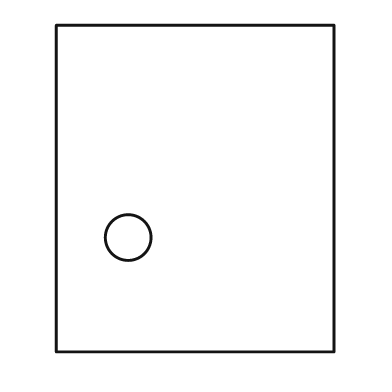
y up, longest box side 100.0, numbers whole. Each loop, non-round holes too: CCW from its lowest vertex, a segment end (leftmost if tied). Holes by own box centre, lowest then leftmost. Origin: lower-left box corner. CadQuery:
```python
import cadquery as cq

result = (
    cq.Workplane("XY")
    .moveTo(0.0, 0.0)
    .lineTo(85.0, 0.0)
    .lineTo(85.0, 100.0)
    .lineTo(0.0, 100.0)
    .close()
    .moveTo(22.0, 35.0)
    .circle(7.0)
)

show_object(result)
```